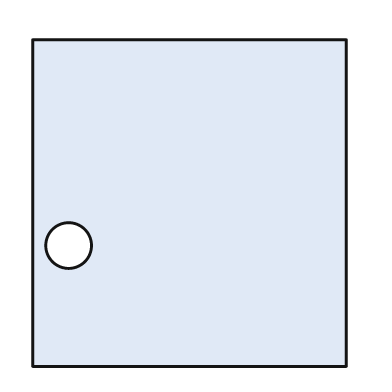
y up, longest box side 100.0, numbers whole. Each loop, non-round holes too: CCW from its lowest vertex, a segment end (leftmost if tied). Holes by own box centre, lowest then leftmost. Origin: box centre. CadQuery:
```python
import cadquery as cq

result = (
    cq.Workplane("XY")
    .moveTo(-48.0, -50.0)
    .lineTo(48.0, -50.0)
    .lineTo(48.0, 50.0)
    .lineTo(-48.0, 50.0)
    .close()
    .moveTo(-37.0, -13.0)
    .circle(7.0)
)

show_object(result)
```